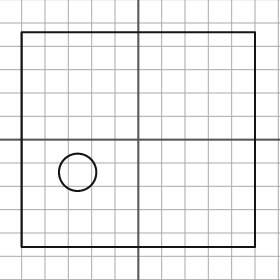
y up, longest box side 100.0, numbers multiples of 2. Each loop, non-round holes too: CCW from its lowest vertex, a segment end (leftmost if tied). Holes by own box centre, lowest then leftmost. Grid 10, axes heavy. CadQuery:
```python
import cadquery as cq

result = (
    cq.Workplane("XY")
    .moveTo(-50.0, -46.0)
    .lineTo(50.0, -46.0)
    .lineTo(50.0, 46.0)
    .lineTo(-50.0, 46.0)
    .close()
    .moveTo(-26.0, -14.0)
    .circle(8.0)
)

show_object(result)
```